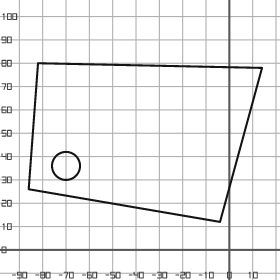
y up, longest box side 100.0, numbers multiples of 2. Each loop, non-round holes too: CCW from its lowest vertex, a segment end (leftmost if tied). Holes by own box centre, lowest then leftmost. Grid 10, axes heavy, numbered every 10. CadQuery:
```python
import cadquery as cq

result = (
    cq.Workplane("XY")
    .moveTo(-4.0, 12.0)
    .lineTo(14.0, 78.0)
    .lineTo(-82.0, 80.0)
    .lineTo(-86.0, 26.0)
    .close()
    .moveTo(-70.0, 36.0)
    .circle(6.0)
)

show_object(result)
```